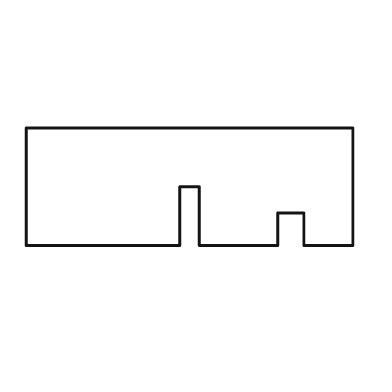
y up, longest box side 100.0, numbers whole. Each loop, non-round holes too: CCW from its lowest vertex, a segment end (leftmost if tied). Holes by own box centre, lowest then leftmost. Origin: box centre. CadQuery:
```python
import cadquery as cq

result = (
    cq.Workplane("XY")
    .moveTo(-50.0, -18.0)
    .lineTo(-3.0, -18.0)
    .lineTo(-3.0, 0.0)
    .lineTo(3.0, 0.0)
    .lineTo(3.0, -18.0)
    .lineTo(27.0, -18.0)
    .lineTo(27.0, -8.0)
    .lineTo(35.0, -8.0)
    .lineTo(35.0, -18.0)
    .lineTo(50.0, -18.0)
    .lineTo(50.0, 18.0)
    .lineTo(-50.0, 18.0)
    .close()
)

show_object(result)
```